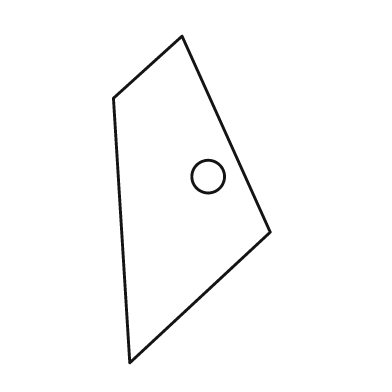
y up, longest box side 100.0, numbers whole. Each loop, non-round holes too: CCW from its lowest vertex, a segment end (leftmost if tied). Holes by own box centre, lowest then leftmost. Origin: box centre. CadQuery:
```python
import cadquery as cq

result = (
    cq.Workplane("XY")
    .moveTo(-19.0, -50.0)
    .lineTo(24.0, -10.0)
    .lineTo(-3.0, 50.0)
    .lineTo(-24.0, 31.0)
    .close()
    .moveTo(5.0, 7.0)
    .circle(5.0)
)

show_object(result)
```